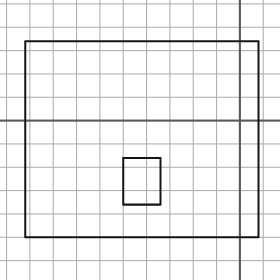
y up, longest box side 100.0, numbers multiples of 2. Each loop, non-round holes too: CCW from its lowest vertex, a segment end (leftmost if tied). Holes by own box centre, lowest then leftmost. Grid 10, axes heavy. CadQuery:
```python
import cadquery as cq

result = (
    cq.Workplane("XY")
    .moveTo(-92.0, -50.0)
    .lineTo(8.0, -50.0)
    .lineTo(8.0, 34.0)
    .lineTo(-92.0, 34.0)
    .close()
    .moveTo(-50.0, -36.0)
    .lineTo(-34.0, -36.0)
    .lineTo(-34.0, -16.0)
    .lineTo(-50.0, -16.0)
    .close()
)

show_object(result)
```